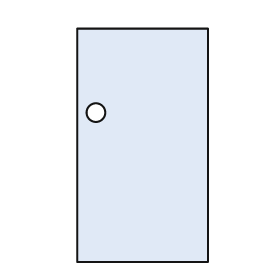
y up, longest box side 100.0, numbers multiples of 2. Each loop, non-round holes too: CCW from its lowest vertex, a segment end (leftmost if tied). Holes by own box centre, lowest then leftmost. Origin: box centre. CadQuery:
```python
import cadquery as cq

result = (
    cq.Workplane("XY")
    .moveTo(-28.0, -50.0)
    .lineTo(28.0, -50.0)
    .lineTo(28.0, 50.0)
    .lineTo(-28.0, 50.0)
    .close()
    .moveTo(-20.0, 14.0)
    .circle(4.0)
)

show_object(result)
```